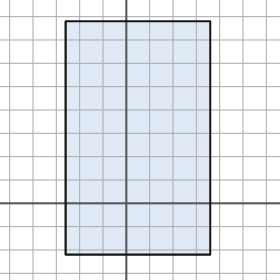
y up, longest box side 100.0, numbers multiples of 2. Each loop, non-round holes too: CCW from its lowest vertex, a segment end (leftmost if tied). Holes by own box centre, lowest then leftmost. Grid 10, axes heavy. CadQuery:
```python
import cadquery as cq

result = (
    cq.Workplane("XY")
    .moveTo(-26.0, -22.0)
    .lineTo(36.0, -22.0)
    .lineTo(36.0, 78.0)
    .lineTo(-26.0, 78.0)
    .close()
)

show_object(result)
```